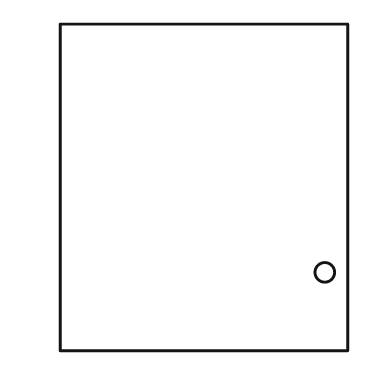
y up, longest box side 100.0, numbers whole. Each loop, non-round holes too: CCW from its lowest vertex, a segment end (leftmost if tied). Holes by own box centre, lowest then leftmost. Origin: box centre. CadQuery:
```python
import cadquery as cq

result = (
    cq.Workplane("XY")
    .moveTo(-44.0, -50.0)
    .lineTo(44.0, -50.0)
    .lineTo(44.0, 50.0)
    .lineTo(-44.0, 50.0)
    .close()
    .moveTo(37.0, -26.0)
    .circle(3.0)
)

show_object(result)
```